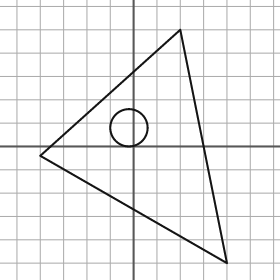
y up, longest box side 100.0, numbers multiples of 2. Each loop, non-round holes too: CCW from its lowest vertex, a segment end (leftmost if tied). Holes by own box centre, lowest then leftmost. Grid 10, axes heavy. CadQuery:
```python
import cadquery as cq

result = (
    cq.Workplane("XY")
    .moveTo(40.0, -50.0)
    .lineTo(20.0, 50.0)
    .lineTo(-40.0, -4.0)
    .close()
    .moveTo(-2.0, 8.0)
    .circle(8.0)
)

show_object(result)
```